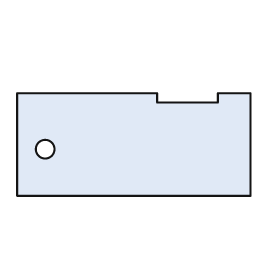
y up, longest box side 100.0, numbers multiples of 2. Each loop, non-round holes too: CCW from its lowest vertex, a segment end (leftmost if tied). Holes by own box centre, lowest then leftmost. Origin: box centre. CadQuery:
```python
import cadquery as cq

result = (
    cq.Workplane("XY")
    .moveTo(-50.0, -22.0)
    .lineTo(50.0, -22.0)
    .lineTo(50.0, 22.0)
    .lineTo(36.0, 22.0)
    .lineTo(36.0, 18.0)
    .lineTo(10.0, 18.0)
    .lineTo(10.0, 22.0)
    .lineTo(-50.0, 22.0)
    .close()
    .moveTo(-38.0, -2.0)
    .circle(4.0)
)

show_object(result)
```